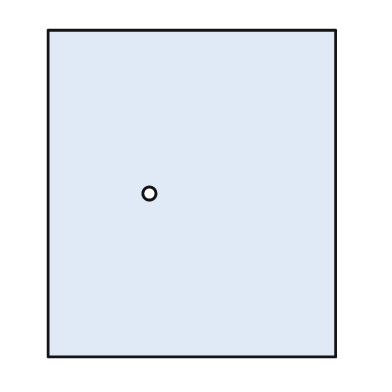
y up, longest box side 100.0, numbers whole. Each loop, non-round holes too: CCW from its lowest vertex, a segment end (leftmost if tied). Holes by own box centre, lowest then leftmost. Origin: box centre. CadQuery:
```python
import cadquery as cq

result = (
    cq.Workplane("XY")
    .moveTo(-44.0, -50.0)
    .lineTo(44.0, -50.0)
    .lineTo(44.0, 50.0)
    .lineTo(-44.0, 50.0)
    .close()
    .moveTo(-13.0, 0.0)
    .circle(2.0)
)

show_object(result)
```